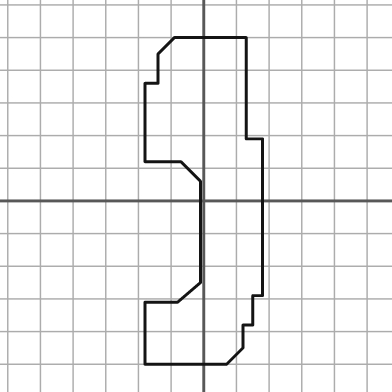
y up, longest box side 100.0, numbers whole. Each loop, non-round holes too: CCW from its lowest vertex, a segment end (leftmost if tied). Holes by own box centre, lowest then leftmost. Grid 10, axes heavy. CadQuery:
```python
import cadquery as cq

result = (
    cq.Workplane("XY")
    .moveTo(-18.0, -50.0)
    .lineTo(7.0, -50.0)
    .lineTo(12.0, -45.0)
    .lineTo(12.0, -38.0)
    .lineTo(15.0, -38.0)
    .lineTo(15.0, -29.0)
    .lineTo(18.0, -29.0)
    .lineTo(18.0, 19.0)
    .lineTo(13.0, 19.0)
    .lineTo(13.0, 50.0)
    .lineTo(-9.0, 50.0)
    .lineTo(-14.0, 45.0)
    .lineTo(-14.0, 36.0)
    .lineTo(-18.0, 36.0)
    .lineTo(-18.0, 12.0)
    .lineTo(-7.0, 12.0)
    .lineTo(-1.0, 6.0)
    .lineTo(-1.0, -25.0)
    .lineTo(-8.0, -31.0)
    .lineTo(-18.0, -31.0)
    .close()
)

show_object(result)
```